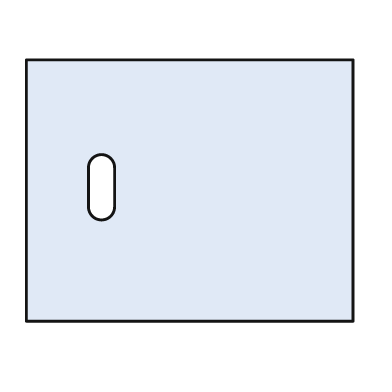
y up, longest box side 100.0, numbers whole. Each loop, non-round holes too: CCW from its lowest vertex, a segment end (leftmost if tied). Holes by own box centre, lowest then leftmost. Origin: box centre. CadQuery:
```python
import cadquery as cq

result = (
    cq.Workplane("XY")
    .moveTo(-50.0, -40.0)
    .lineTo(50.0, -40.0)
    .lineTo(50.0, 40.0)
    .lineTo(-50.0, 40.0)
    .close()
    .moveTo(-31.0, -5.0)
    .threePointArc((-27.0, -9.0), (-23.0, -5.0))
    .lineTo(-23.0, 7.0)
    .threePointArc((-27.0, 11.0), (-31.0, 7.0))
    .close()
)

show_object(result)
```